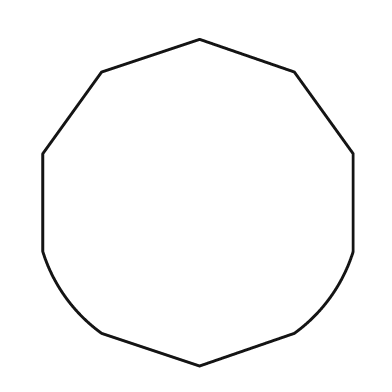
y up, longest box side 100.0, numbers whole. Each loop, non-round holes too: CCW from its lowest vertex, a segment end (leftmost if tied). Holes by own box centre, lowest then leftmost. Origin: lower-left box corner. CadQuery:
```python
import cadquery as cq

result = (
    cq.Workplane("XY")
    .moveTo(48.0, 0.0)
    .lineTo(77.0, 10.0)
    .threePointArc((88.0, 21.0), (95.0, 35.0))
    .lineTo(95.0, 65.0)
    .lineTo(77.0, 90.0)
    .lineTo(48.0, 100.0)
    .lineTo(18.0, 90.0)
    .lineTo(0.0, 65.0)
    .lineTo(0.0, 35.0)
    .threePointArc((7.0, 21.0), (18.0, 10.0))
    .close()
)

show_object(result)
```